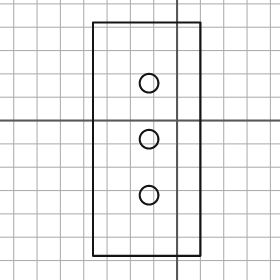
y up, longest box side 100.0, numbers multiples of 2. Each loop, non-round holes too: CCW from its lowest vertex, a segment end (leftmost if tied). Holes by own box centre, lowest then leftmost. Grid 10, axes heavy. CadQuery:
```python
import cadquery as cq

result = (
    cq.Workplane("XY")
    .moveTo(-36.0, -58.0)
    .lineTo(10.0, -58.0)
    .lineTo(10.0, 42.0)
    .lineTo(-36.0, 42.0)
    .close()
    .moveTo(-12.0, -32.0)
    .circle(4.0)
    .moveTo(-12.0, -8.0)
    .circle(4.0)
    .moveTo(-12.0, 16.0)
    .circle(4.0)
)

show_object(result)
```